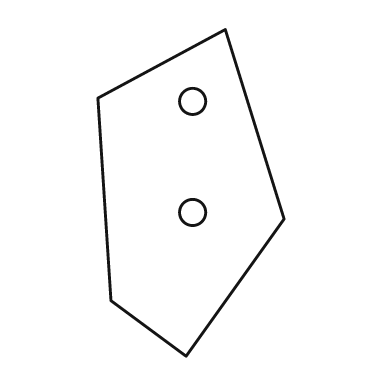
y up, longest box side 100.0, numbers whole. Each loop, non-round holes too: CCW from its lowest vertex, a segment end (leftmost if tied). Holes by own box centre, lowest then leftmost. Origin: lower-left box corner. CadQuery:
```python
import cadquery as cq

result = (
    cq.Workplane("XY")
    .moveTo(27.0, 0.0)
    .lineTo(57.0, 42.0)
    .lineTo(39.0, 100.0)
    .lineTo(0.0, 79.0)
    .lineTo(4.0, 17.0)
    .close()
    .moveTo(29.0, 44.0)
    .circle(4.0)
    .moveTo(29.0, 78.0)
    .circle(4.0)
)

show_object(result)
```